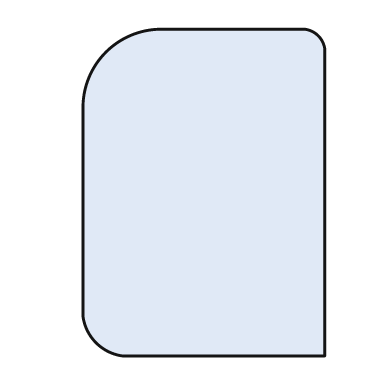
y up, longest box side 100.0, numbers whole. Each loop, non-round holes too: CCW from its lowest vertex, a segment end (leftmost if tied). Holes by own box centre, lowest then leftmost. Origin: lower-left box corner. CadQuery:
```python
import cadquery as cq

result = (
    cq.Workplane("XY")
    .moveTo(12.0, 0.0)
    .lineTo(74.0, 0.0)
    .lineTo(74.0, 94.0)
    .threePointArc((72.0, 98.0), (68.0, 100.0))
    .lineTo(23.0, 100.0)
    .threePointArc((7.0, 93.0), (0.0, 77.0))
    .lineTo(0.0, 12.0)
    .threePointArc((4.0, 4.0), (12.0, 0.0))
    .close()
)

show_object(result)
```